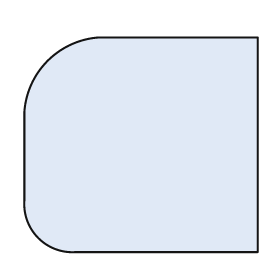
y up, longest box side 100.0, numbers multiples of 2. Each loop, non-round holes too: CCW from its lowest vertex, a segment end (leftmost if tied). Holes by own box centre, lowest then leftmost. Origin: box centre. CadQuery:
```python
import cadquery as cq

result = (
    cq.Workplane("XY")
    .moveTo(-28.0, -46.0)
    .lineTo(50.0, -46.0)
    .lineTo(50.0, 46.0)
    .lineTo(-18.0, 46.0)
    .threePointArc((-40.0, 36.0), (-50.0, 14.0))
    .lineTo(-50.0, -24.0)
    .threePointArc((-44.0, -40.0), (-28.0, -46.0))
    .close()
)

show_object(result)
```